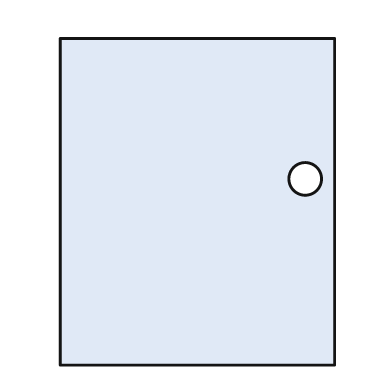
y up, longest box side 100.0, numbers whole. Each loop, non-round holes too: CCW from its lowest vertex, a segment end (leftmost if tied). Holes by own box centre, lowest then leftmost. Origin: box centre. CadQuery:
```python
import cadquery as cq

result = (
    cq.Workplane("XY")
    .moveTo(-42.0, -50.0)
    .lineTo(42.0, -50.0)
    .lineTo(42.0, 50.0)
    .lineTo(-42.0, 50.0)
    .close()
    .moveTo(33.0, 7.0)
    .circle(5.0)
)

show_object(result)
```